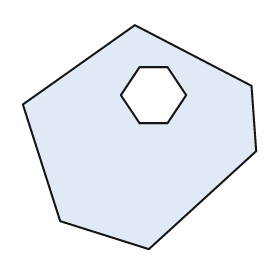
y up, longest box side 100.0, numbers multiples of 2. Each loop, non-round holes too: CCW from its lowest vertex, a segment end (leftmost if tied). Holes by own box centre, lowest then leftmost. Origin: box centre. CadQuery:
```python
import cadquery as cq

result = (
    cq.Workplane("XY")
    .moveTo(4.0, -48.0)
    .lineTo(50.0, -6.0)
    .lineTo(48.0, 22.0)
    .lineTo(-2.0, 48.0)
    .lineTo(-50.0, 14.0)
    .lineTo(-34.0, -36.0)
    .close()
    .moveTo(0.0, 6.0)
    .lineTo(12.0, 6.0)
    .lineTo(20.0, 18.0)
    .lineTo(12.0, 30.0)
    .lineTo(0.0, 30.0)
    .lineTo(-8.0, 18.0)
    .close()
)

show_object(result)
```